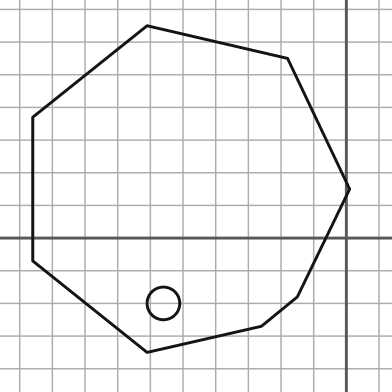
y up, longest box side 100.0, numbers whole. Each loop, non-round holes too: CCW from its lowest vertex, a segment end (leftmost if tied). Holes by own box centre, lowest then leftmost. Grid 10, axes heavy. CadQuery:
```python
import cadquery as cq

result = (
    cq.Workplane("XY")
    .moveTo(-61.0, -35.0)
    .lineTo(-26.0, -27.0)
    .lineTo(-15.0, -18.0)
    .lineTo(1.0, 15.0)
    .lineTo(-18.0, 55.0)
    .lineTo(-61.0, 65.0)
    .lineTo(-96.0, 37.0)
    .lineTo(-96.0, -7.0)
    .close()
    .moveTo(-56.0, -20.0)
    .circle(5.0)
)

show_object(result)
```